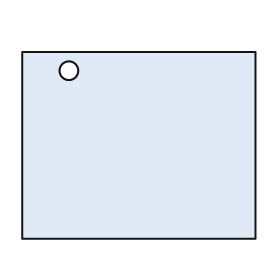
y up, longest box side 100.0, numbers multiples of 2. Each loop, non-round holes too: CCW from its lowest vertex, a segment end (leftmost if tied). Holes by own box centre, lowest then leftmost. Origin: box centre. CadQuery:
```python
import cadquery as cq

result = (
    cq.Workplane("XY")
    .moveTo(-50.0, -40.0)
    .lineTo(50.0, -40.0)
    .lineTo(50.0, 40.0)
    .lineTo(-50.0, 40.0)
    .close()
    .moveTo(-30.0, 32.0)
    .circle(4.0)
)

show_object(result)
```